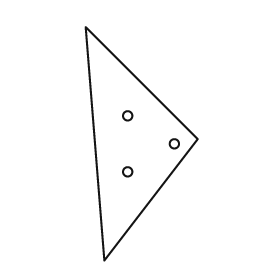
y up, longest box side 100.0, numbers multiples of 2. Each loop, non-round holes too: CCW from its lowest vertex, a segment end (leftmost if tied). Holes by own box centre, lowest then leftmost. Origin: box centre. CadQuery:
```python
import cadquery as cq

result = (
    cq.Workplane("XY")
    .moveTo(-16.0, -50.0)
    .lineTo(24.0, 2.0)
    .lineTo(-24.0, 50.0)
    .close()
    .moveTo(-6.0, -12.0)
    .circle(2.0)
    .moveTo(14.0, 0.0)
    .circle(2.0)
    .moveTo(-6.0, 12.0)
    .circle(2.0)
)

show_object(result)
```